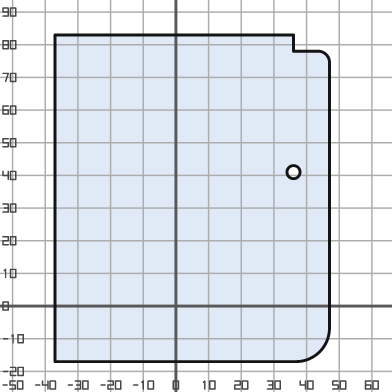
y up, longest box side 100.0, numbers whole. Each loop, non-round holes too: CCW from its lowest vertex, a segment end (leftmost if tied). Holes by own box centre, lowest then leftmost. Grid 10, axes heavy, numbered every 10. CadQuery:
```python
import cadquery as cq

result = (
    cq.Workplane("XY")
    .moveTo(-37.0, -17.0)
    .lineTo(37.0, -17.0)
    .threePointArc((44.0, -14.0), (47.0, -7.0))
    .lineTo(47.0, 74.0)
    .threePointArc((46.0, 77.0), (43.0, 78.0))
    .lineTo(36.0, 78.0)
    .lineTo(36.0, 83.0)
    .lineTo(-37.0, 83.0)
    .close()
    .moveTo(36.0, 41.0)
    .circle(2.0)
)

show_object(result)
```